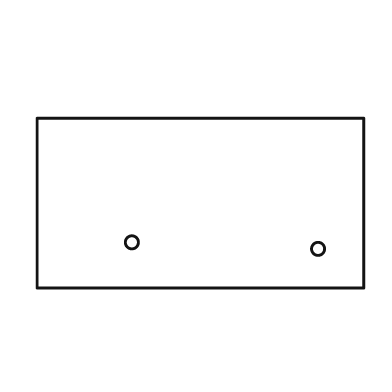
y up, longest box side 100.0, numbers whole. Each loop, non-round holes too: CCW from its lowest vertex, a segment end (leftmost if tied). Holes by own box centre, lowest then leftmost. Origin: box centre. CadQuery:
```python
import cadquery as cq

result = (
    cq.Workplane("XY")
    .moveTo(-50.0, -26.0)
    .lineTo(50.0, -26.0)
    .lineTo(50.0, 26.0)
    .lineTo(-50.0, 26.0)
    .close()
    .moveTo(36.0, -14.0)
    .circle(2.0)
    .moveTo(-21.0, -12.0)
    .circle(2.0)
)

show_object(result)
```